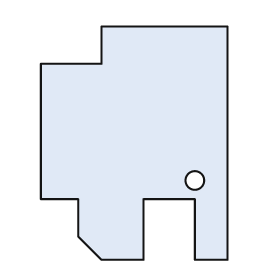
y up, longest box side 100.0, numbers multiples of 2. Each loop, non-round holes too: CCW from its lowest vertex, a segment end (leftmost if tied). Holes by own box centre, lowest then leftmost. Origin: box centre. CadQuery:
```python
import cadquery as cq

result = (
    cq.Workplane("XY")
    .moveTo(-14.0, -50.0)
    .lineTo(4.0, -50.0)
    .lineTo(4.0, -24.0)
    .lineTo(26.0, -24.0)
    .lineTo(26.0, -50.0)
    .lineTo(40.0, -50.0)
    .lineTo(40.0, 50.0)
    .lineTo(-14.0, 50.0)
    .lineTo(-14.0, 34.0)
    .lineTo(-40.0, 34.0)
    .lineTo(-40.0, -24.0)
    .lineTo(-24.0, -24.0)
    .lineTo(-24.0, -40.0)
    .close()
    .moveTo(26.0, -16.0)
    .circle(4.0)
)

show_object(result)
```